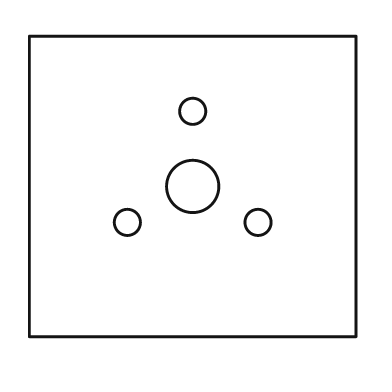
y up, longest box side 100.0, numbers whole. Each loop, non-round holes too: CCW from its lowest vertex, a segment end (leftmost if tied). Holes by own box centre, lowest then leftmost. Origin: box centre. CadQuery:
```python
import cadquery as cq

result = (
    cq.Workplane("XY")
    .moveTo(-50.0, -46.0)
    .lineTo(50.0, -46.0)
    .lineTo(50.0, 46.0)
    .lineTo(-50.0, 46.0)
    .close()
    .moveTo(-20.0, -11.0)
    .circle(4.0)
    .moveTo(20.0, -11.0)
    .circle(4.0)
    .moveTo(0.0, 0.0)
    .circle(8.0)
    .moveTo(0.0, 23.0)
    .circle(4.0)
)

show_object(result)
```